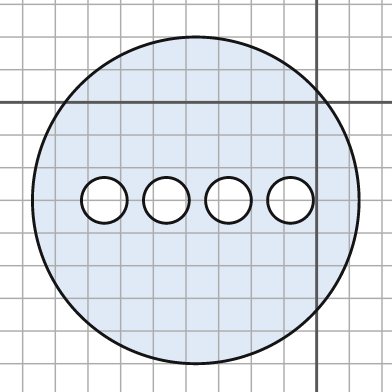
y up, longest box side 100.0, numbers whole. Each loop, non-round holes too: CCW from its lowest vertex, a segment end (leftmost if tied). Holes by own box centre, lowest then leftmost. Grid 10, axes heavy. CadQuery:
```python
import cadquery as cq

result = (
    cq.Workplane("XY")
    .moveTo(-37.0, -30.0)
    .circle(50.0)
    .moveTo(-65.0, -30.0)
    .circle(7.0)
    .moveTo(-46.0, -30.0)
    .circle(7.0)
    .moveTo(-27.0, -30.0)
    .circle(7.0)
    .moveTo(-8.0, -30.0)
    .circle(7.0)
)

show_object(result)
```